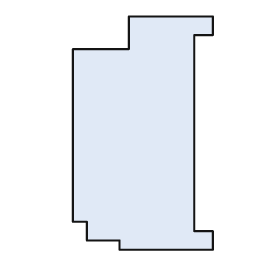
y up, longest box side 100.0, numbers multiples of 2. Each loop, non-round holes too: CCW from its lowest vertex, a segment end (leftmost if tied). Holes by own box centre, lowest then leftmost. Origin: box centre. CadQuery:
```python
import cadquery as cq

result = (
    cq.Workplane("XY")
    .moveTo(-10.0, -50.0)
    .lineTo(30.0, -50.0)
    .lineTo(30.0, -42.0)
    .lineTo(22.0, -42.0)
    .lineTo(22.0, 42.0)
    .lineTo(30.0, 42.0)
    .lineTo(30.0, 50.0)
    .lineTo(-6.0, 50.0)
    .lineTo(-6.0, 36.0)
    .lineTo(-30.0, 36.0)
    .lineTo(-30.0, -38.0)
    .lineTo(-24.0, -38.0)
    .lineTo(-24.0, -46.0)
    .lineTo(-10.0, -46.0)
    .close()
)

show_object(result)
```